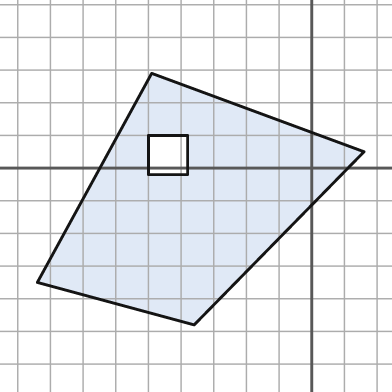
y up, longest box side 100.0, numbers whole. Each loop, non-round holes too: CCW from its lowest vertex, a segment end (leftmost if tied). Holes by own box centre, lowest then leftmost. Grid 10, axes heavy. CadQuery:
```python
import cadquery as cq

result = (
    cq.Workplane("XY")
    .moveTo(-36.0, -48.0)
    .lineTo(16.0, 5.0)
    .lineTo(-49.0, 29.0)
    .lineTo(-84.0, -35.0)
    .close()
    .moveTo(-50.0, -2.0)
    .lineTo(-38.0, -2.0)
    .lineTo(-38.0, 10.0)
    .lineTo(-50.0, 10.0)
    .close()
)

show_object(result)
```